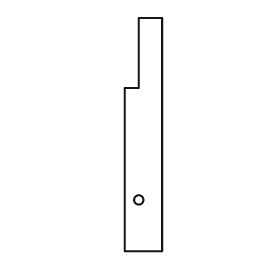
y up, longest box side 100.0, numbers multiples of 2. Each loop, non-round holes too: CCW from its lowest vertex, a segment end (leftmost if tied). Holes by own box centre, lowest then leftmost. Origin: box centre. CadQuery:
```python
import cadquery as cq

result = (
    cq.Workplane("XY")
    .moveTo(-8.0, -50.0)
    .lineTo(8.0, -50.0)
    .lineTo(8.0, 50.0)
    .lineTo(-2.0, 50.0)
    .lineTo(-2.0, 20.0)
    .lineTo(-8.0, 20.0)
    .close()
    .moveTo(-2.0, -28.0)
    .circle(2.0)
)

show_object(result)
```